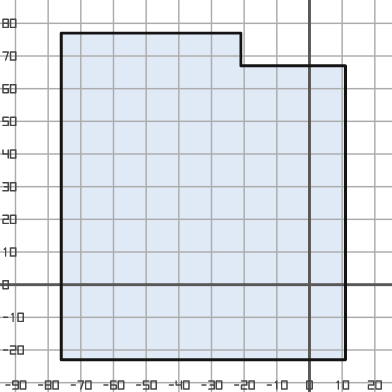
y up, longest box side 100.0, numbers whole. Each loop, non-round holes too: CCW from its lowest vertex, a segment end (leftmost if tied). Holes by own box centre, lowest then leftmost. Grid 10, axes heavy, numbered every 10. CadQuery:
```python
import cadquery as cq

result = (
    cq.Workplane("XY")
    .moveTo(-76.0, -23.0)
    .lineTo(11.0, -23.0)
    .lineTo(11.0, 67.0)
    .lineTo(-21.0, 67.0)
    .lineTo(-21.0, 77.0)
    .lineTo(-76.0, 77.0)
    .close()
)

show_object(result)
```